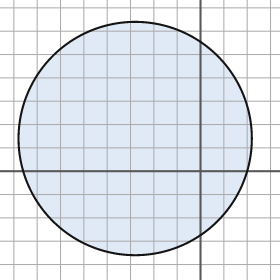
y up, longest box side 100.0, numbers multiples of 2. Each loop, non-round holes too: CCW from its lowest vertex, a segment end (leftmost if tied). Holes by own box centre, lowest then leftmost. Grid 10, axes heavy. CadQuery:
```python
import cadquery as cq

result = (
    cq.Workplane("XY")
    .moveTo(-28.0, 14.0)
    .circle(50.0)
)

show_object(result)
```